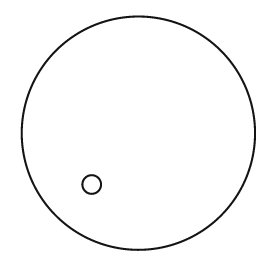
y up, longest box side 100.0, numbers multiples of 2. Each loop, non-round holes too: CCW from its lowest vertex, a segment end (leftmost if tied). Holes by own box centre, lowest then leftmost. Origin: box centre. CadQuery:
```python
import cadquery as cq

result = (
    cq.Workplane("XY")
    .moveTo(0.0, 0.0)
    .circle(50.0)
    .moveTo(-20.0, -22.0)
    .circle(4.0)
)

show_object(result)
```